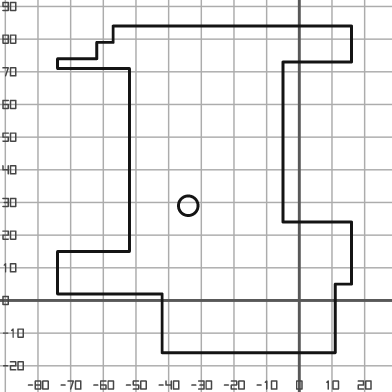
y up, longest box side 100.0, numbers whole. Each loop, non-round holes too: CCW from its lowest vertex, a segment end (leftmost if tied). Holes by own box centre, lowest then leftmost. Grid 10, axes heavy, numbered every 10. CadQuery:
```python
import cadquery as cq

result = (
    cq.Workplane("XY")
    .moveTo(-42.0, -16.0)
    .lineTo(11.0, -16.0)
    .lineTo(11.0, 5.0)
    .lineTo(16.0, 5.0)
    .lineTo(16.0, 24.0)
    .lineTo(-5.0, 24.0)
    .lineTo(-5.0, 73.0)
    .lineTo(16.0, 73.0)
    .lineTo(16.0, 84.0)
    .lineTo(-57.0, 84.0)
    .lineTo(-57.0, 79.0)
    .lineTo(-62.0, 79.0)
    .lineTo(-62.0, 74.0)
    .lineTo(-74.0, 74.0)
    .lineTo(-74.0, 71.0)
    .lineTo(-52.0, 71.0)
    .lineTo(-52.0, 15.0)
    .lineTo(-74.0, 15.0)
    .lineTo(-74.0, 2.0)
    .lineTo(-42.0, 2.0)
    .close()
    .moveTo(-34.0, 29.0)
    .circle(3.0)
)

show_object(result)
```